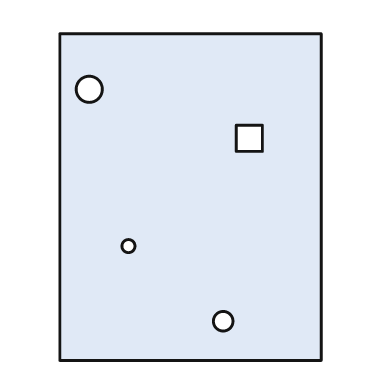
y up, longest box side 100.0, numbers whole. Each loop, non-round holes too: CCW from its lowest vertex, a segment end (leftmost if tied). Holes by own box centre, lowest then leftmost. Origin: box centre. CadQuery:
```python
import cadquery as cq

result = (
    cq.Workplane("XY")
    .moveTo(-40.0, -50.0)
    .lineTo(40.0, -50.0)
    .lineTo(40.0, 50.0)
    .lineTo(-40.0, 50.0)
    .close()
    .moveTo(10.0, -38.0)
    .circle(3.0)
    .moveTo(-19.0, -15.0)
    .circle(2.0)
    .moveTo(14.0, 14.0)
    .lineTo(22.0, 14.0)
    .lineTo(22.0, 22.0)
    .lineTo(14.0, 22.0)
    .close()
    .moveTo(-31.0, 33.0)
    .circle(4.0)
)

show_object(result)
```